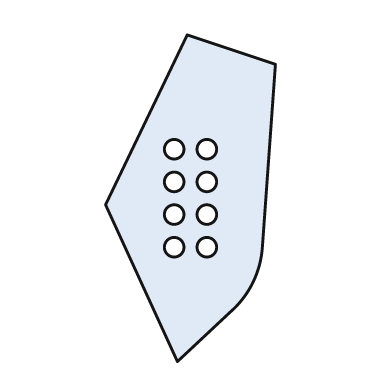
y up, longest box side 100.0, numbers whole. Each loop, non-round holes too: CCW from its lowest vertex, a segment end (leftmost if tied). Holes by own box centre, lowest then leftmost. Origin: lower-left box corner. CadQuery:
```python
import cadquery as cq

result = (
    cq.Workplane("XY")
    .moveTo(22.0, 0.0)
    .lineTo(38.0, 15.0)
    .threePointArc((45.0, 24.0), (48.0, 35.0))
    .lineTo(52.0, 91.0)
    .lineTo(25.0, 100.0)
    .lineTo(0.0, 48.0)
    .close()
    .moveTo(21.0, 35.0)
    .circle(3.0)
    .moveTo(31.0, 35.0)
    .circle(3.0)
    .moveTo(21.0, 45.0)
    .circle(3.0)
    .moveTo(31.0, 45.0)
    .circle(3.0)
    .moveTo(21.0, 55.0)
    .circle(3.0)
    .moveTo(31.0, 55.0)
    .circle(3.0)
    .moveTo(21.0, 65.0)
    .circle(3.0)
    .moveTo(31.0, 65.0)
    .circle(3.0)
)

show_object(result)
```